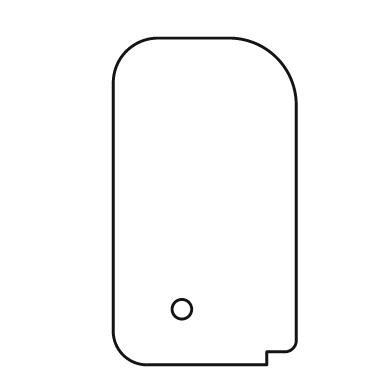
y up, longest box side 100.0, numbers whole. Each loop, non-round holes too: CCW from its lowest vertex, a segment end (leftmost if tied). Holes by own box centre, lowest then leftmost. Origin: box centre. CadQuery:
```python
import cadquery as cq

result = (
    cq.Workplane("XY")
    .moveTo(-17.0, -50.0)
    .lineTo(19.0, -50.0)
    .lineTo(19.0, -46.0)
    .lineTo(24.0, -46.0)
    .threePointArc((27.0, -45.0), (28.0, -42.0))
    .lineTo(28.0, 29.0)
    .threePointArc((22.0, 44.0), (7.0, 50.0))
    .lineTo(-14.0, 50.0)
    .threePointArc((-24.0, 46.0), (-28.0, 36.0))
    .lineTo(-28.0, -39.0)
    .threePointArc((-25.0, -47.0), (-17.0, -50.0))
    .close()
    .moveTo(-7.0, -33.0)
    .circle(3.0)
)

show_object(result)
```